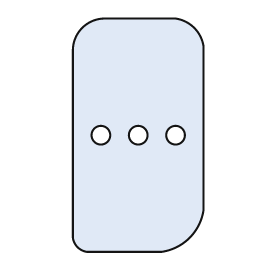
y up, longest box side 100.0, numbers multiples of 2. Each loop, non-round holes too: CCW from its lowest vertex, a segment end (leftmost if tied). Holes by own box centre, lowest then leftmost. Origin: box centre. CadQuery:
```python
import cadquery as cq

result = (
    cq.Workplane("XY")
    .moveTo(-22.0, -50.0)
    .lineTo(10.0, -50.0)
    .threePointArc((22.0, -44.0), (28.0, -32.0))
    .lineTo(28.0, 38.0)
    .threePointArc((24.0, 46.0), (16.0, 50.0))
    .lineTo(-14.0, 50.0)
    .threePointArc((-24.0, 46.0), (-28.0, 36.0))
    .lineTo(-28.0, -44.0)
    .threePointArc((-26.0, -48.0), (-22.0, -50.0))
    .close()
    .moveTo(-16.0, 0.0)
    .circle(4.0)
    .moveTo(0.0, 0.0)
    .circle(4.0)
    .moveTo(16.0, 0.0)
    .circle(4.0)
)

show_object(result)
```